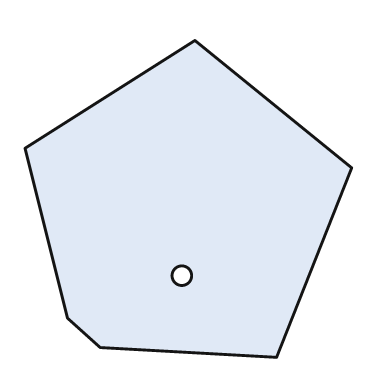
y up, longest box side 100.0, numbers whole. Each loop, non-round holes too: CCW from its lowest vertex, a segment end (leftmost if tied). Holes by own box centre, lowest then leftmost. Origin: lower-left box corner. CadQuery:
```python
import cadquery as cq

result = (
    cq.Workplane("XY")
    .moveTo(77.0, 0.0)
    .lineTo(100.0, 58.0)
    .lineTo(52.0, 97.0)
    .lineTo(0.0, 64.0)
    .lineTo(13.0, 12.0)
    .lineTo(23.0, 3.0)
    .close()
    .moveTo(48.0, 25.0)
    .circle(3.0)
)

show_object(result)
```